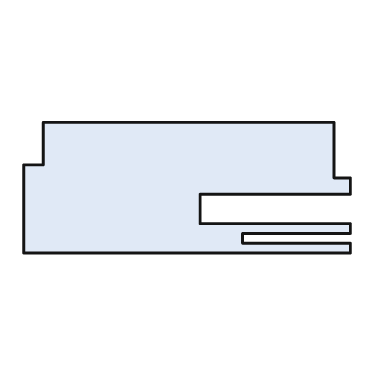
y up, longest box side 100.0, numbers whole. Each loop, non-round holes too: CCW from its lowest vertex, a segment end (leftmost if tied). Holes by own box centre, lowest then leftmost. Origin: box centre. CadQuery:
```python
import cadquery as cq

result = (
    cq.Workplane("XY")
    .moveTo(-50.0, -20.0)
    .lineTo(50.0, -20.0)
    .lineTo(50.0, -17.0)
    .lineTo(17.0, -17.0)
    .lineTo(17.0, -14.0)
    .lineTo(50.0, -14.0)
    .lineTo(50.0, -11.0)
    .lineTo(4.0, -11.0)
    .lineTo(4.0, -2.0)
    .lineTo(50.0, -2.0)
    .lineTo(50.0, 3.0)
    .lineTo(45.0, 3.0)
    .lineTo(45.0, 20.0)
    .lineTo(-44.0, 20.0)
    .lineTo(-44.0, 7.0)
    .lineTo(-50.0, 7.0)
    .close()
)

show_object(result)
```